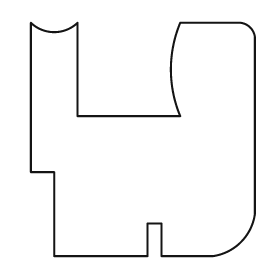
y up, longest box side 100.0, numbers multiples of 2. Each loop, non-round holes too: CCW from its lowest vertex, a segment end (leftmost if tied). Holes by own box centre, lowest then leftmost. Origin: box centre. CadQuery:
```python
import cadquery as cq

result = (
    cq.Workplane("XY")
    .moveTo(-38.0, -50.0)
    .lineTo(2.0, -50.0)
    .lineTo(2.0, -36.0)
    .lineTo(8.0, -36.0)
    .lineTo(8.0, -50.0)
    .lineTo(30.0, -50.0)
    .threePointArc((42.0, -44.0), (48.0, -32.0))
    .lineTo(48.0, 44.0)
    .threePointArc((46.0, 48.0), (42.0, 50.0))
    .lineTo(16.0, 50.0)
    .threePointArc((12.0, 30.0), (16.0, 10.0))
    .lineTo(-28.0, 10.0)
    .lineTo(-28.0, 50.0)
    .threePointArc((-38.0, 46.0), (-48.0, 50.0))
    .lineTo(-48.0, -14.0)
    .lineTo(-38.0, -14.0)
    .close()
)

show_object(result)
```